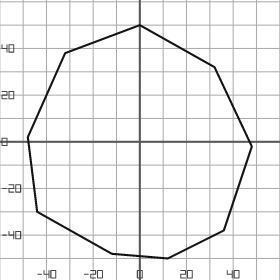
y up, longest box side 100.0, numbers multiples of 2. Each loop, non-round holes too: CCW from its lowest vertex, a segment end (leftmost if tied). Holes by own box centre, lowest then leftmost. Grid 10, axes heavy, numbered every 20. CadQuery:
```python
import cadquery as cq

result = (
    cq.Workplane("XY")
    .moveTo(12.0, -50.0)
    .lineTo(36.0, -38.0)
    .lineTo(48.0, -2.0)
    .lineTo(32.0, 32.0)
    .lineTo(0.0, 50.0)
    .lineTo(-32.0, 38.0)
    .lineTo(-48.0, 2.0)
    .lineTo(-44.0, -30.0)
    .lineTo(-12.0, -48.0)
    .close()
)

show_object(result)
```